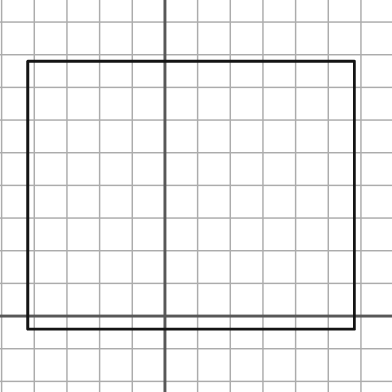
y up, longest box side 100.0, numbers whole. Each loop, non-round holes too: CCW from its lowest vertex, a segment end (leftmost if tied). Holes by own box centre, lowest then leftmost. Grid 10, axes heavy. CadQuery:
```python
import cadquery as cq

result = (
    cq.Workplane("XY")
    .moveTo(-42.0, -4.0)
    .lineTo(58.0, -4.0)
    .lineTo(58.0, 78.0)
    .lineTo(-42.0, 78.0)
    .close()
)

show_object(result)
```